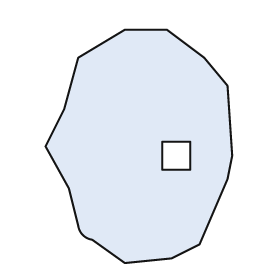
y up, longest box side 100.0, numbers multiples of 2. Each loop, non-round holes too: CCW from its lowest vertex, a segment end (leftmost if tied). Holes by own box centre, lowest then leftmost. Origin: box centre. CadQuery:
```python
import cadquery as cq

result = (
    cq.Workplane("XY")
    .moveTo(-6.0, -50.0)
    .lineTo(14.0, -48.0)
    .lineTo(26.0, -42.0)
    .lineTo(38.0, -14.0)
    .lineTo(40.0, -4.0)
    .lineTo(38.0, 26.0)
    .lineTo(28.0, 38.0)
    .lineTo(12.0, 50.0)
    .lineTo(-6.0, 50.0)
    .lineTo(-26.0, 38.0)
    .lineTo(-32.0, 16.0)
    .lineTo(-40.0, 0.0)
    .lineTo(-30.0, -18.0)
    .lineTo(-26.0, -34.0)
    .threePointArc((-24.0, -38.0), (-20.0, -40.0))
    .close()
    .moveTo(10.0, -10.0)
    .lineTo(22.0, -10.0)
    .lineTo(22.0, 2.0)
    .lineTo(10.0, 2.0)
    .close()
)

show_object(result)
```